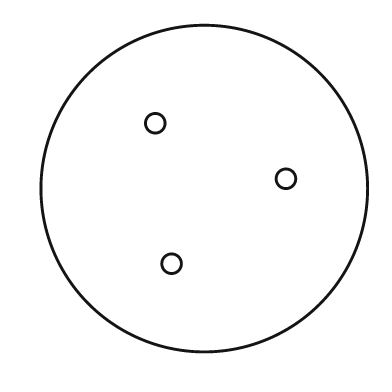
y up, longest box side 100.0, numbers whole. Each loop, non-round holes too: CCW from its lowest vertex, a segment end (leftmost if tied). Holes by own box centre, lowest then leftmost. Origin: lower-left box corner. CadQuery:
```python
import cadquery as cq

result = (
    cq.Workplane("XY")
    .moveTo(50.0, 50.0)
    .circle(50.0)
    .moveTo(40.0, 27.0)
    .circle(3.0)
    .moveTo(75.0, 53.0)
    .circle(3.0)
    .moveTo(35.0, 70.0)
    .circle(3.0)
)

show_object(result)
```